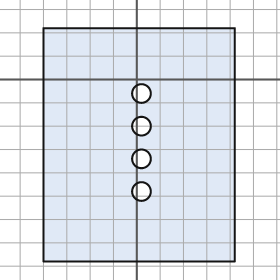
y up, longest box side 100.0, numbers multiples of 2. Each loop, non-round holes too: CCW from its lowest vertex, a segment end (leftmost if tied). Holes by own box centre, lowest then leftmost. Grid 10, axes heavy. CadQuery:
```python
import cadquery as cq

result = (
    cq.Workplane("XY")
    .moveTo(-40.0, -78.0)
    .lineTo(42.0, -78.0)
    .lineTo(42.0, 22.0)
    .lineTo(-40.0, 22.0)
    .close()
    .moveTo(2.0, -48.0)
    .circle(4.0)
    .moveTo(2.0, -34.0)
    .circle(4.0)
    .moveTo(2.0, -20.0)
    .circle(4.0)
    .moveTo(2.0, -6.0)
    .circle(4.0)
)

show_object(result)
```